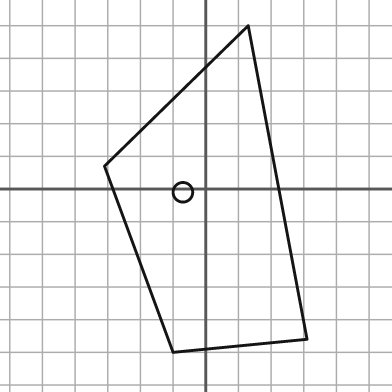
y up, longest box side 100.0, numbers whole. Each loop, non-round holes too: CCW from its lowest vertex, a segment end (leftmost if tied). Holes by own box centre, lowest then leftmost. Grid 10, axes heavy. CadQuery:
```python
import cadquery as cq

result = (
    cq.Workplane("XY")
    .moveTo(-10.0, -50.0)
    .lineTo(31.0, -46.0)
    .lineTo(13.0, 50.0)
    .lineTo(-31.0, 7.0)
    .close()
    .moveTo(-7.0, -1.0)
    .circle(3.0)
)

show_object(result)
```